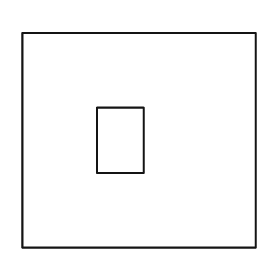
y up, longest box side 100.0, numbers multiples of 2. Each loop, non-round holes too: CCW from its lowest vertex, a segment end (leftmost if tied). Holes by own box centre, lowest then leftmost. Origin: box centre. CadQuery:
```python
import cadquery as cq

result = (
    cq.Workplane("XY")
    .moveTo(-50.0, -46.0)
    .lineTo(50.0, -46.0)
    .lineTo(50.0, 46.0)
    .lineTo(-50.0, 46.0)
    .close()
    .moveTo(-18.0, -14.0)
    .lineTo(2.0, -14.0)
    .lineTo(2.0, 14.0)
    .lineTo(-18.0, 14.0)
    .close()
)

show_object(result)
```